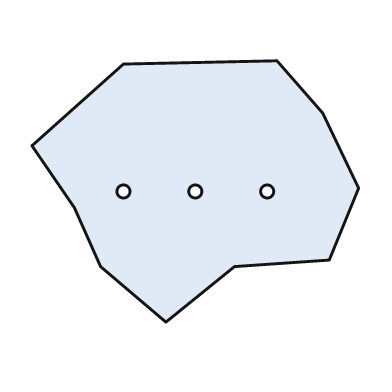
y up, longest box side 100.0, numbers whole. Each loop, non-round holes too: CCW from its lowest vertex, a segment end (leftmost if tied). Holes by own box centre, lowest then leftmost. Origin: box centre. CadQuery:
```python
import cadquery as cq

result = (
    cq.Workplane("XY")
    .moveTo(-9.0, -40.0)
    .lineTo(12.0, -23.0)
    .lineTo(41.0, -21.0)
    .lineTo(50.0, 1.0)
    .lineTo(39.0, 24.0)
    .lineTo(25.0, 40.0)
    .lineTo(-22.0, 39.0)
    .lineTo(-50.0, 14.0)
    .lineTo(-37.0, -5.0)
    .lineTo(-29.0, -23.0)
    .close()
    .moveTo(-22.0, 0.0)
    .circle(2.0)
    .moveTo(0.0, 0.0)
    .circle(2.0)
    .moveTo(22.0, 0.0)
    .circle(2.0)
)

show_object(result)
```